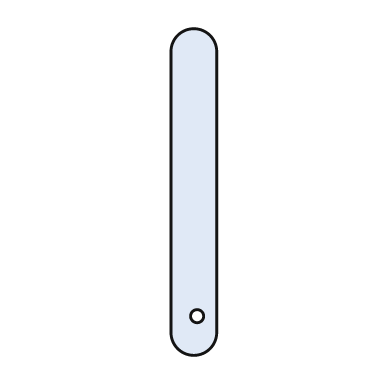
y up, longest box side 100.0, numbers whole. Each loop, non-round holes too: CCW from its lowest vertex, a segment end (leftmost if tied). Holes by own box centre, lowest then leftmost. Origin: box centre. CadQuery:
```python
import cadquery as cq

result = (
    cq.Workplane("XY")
    .moveTo(-7.0, -43.0)
    .threePointArc((0.0, -50.0), (7.0, -43.0))
    .lineTo(7.0, 43.0)
    .threePointArc((0.0, 50.0), (-7.0, 43.0))
    .close()
    .moveTo(1.0, -38.0)
    .circle(2.0)
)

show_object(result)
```